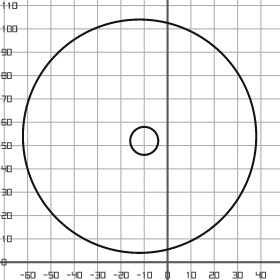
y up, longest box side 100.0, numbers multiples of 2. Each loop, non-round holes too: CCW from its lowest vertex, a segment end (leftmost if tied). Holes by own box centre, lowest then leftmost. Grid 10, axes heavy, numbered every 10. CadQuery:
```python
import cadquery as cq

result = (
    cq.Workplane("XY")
    .moveTo(-12.0, 54.0)
    .circle(50.0)
    .moveTo(-10.0, 52.0)
    .circle(6.0)
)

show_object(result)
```